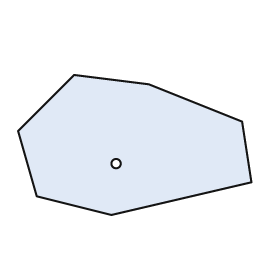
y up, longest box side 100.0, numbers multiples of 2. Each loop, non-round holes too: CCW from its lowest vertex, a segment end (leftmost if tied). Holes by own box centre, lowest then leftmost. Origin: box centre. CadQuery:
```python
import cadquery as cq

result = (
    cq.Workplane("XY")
    .moveTo(-10.0, -30.0)
    .lineTo(50.0, -16.0)
    .lineTo(46.0, 10.0)
    .lineTo(6.0, 26.0)
    .lineTo(-26.0, 30.0)
    .lineTo(-50.0, 6.0)
    .lineTo(-42.0, -22.0)
    .close()
    .moveTo(-8.0, -8.0)
    .circle(2.0)
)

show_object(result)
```